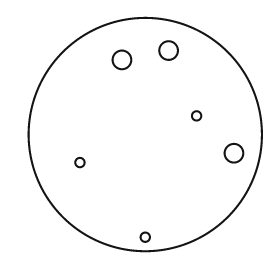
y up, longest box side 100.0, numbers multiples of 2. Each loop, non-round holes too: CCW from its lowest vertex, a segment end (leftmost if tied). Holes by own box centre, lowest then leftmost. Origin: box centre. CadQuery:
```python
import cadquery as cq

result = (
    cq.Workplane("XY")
    .moveTo(0.0, 0.0)
    .circle(50.0)
    .moveTo(0.0, -44.0)
    .circle(2.0)
    .moveTo(-28.0, -12.0)
    .circle(2.0)
    .moveTo(38.0, -8.0)
    .circle(4.0)
    .moveTo(22.0, 8.0)
    .circle(2.0)
    .moveTo(-10.0, 32.0)
    .circle(4.0)
    .moveTo(10.0, 36.0)
    .circle(4.0)
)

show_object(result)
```